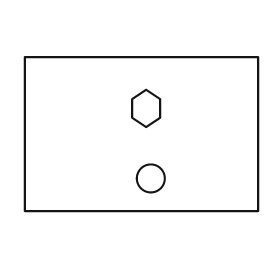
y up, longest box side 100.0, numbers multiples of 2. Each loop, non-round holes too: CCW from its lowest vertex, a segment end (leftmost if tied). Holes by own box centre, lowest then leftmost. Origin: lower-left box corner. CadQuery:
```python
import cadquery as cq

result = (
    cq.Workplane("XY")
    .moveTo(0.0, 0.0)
    .lineTo(100.0, 0.0)
    .lineTo(100.0, 66.0)
    .lineTo(0.0, 66.0)
    .close()
    .moveTo(54.0, 14.0)
    .circle(6.0)
    .moveTo(52.0, 36.0)
    .lineTo(58.0, 40.0)
    .lineTo(58.0, 48.0)
    .lineTo(52.0, 52.0)
    .lineTo(46.0, 48.0)
    .lineTo(46.0, 40.0)
    .close()
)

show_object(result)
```